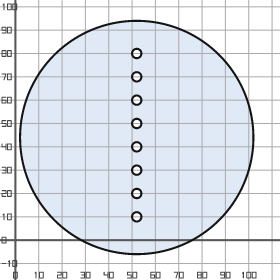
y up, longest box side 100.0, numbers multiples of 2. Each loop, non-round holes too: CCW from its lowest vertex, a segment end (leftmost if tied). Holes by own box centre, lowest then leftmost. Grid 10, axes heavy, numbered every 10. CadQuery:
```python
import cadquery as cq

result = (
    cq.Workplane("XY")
    .moveTo(52.0, 44.0)
    .circle(50.0)
    .moveTo(52.0, 10.0)
    .circle(2.0)
    .moveTo(52.0, 20.0)
    .circle(2.0)
    .moveTo(52.0, 30.0)
    .circle(2.0)
    .moveTo(52.0, 40.0)
    .circle(2.0)
    .moveTo(52.0, 50.0)
    .circle(2.0)
    .moveTo(52.0, 60.0)
    .circle(2.0)
    .moveTo(52.0, 70.0)
    .circle(2.0)
    .moveTo(52.0, 80.0)
    .circle(2.0)
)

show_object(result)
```